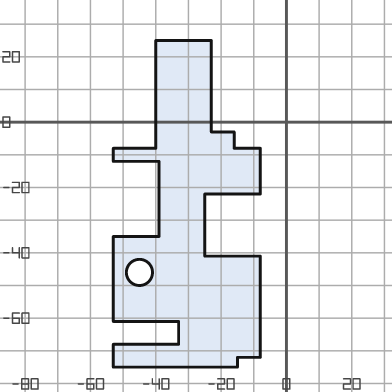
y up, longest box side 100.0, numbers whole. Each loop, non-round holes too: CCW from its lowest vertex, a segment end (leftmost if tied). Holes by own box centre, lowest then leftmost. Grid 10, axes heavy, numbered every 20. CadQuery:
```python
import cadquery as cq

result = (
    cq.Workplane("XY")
    .moveTo(-53.0, -75.0)
    .lineTo(-15.0, -75.0)
    .lineTo(-15.0, -72.0)
    .lineTo(-8.0, -72.0)
    .lineTo(-8.0, -41.0)
    .lineTo(-25.0, -41.0)
    .lineTo(-25.0, -22.0)
    .lineTo(-8.0, -22.0)
    .lineTo(-8.0, -8.0)
    .lineTo(-16.0, -8.0)
    .lineTo(-16.0, -3.0)
    .lineTo(-23.0, -3.0)
    .lineTo(-23.0, 25.0)
    .lineTo(-40.0, 25.0)
    .lineTo(-40.0, -8.0)
    .lineTo(-53.0, -8.0)
    .lineTo(-53.0, -12.0)
    .lineTo(-39.0, -12.0)
    .lineTo(-39.0, -35.0)
    .lineTo(-53.0, -35.0)
    .lineTo(-53.0, -61.0)
    .lineTo(-33.0, -61.0)
    .lineTo(-33.0, -68.0)
    .lineTo(-53.0, -68.0)
    .close()
    .moveTo(-45.0, -46.0)
    .circle(4.0)
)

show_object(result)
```